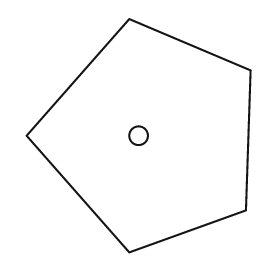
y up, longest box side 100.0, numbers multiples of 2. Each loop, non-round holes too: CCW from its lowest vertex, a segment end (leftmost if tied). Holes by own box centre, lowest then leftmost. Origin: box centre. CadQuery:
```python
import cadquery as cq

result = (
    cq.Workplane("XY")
    .moveTo(-4.0, -50.0)
    .lineTo(46.0, -32.0)
    .lineTo(48.0, 28.0)
    .lineTo(-4.0, 50.0)
    .lineTo(-48.0, 0.0)
    .close()
    .moveTo(0.0, 0.0)
    .circle(4.0)
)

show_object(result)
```